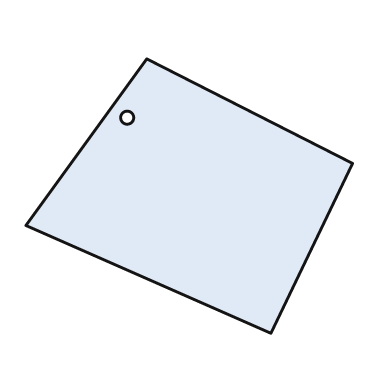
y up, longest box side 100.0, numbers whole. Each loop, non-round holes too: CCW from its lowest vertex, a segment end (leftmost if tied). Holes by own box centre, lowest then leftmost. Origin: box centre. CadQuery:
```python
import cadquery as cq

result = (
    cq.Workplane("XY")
    .moveTo(25.0, -42.0)
    .lineTo(50.0, 10.0)
    .lineTo(-13.0, 42.0)
    .lineTo(-50.0, -9.0)
    .close()
    .moveTo(-19.0, 24.0)
    .circle(2.0)
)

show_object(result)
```